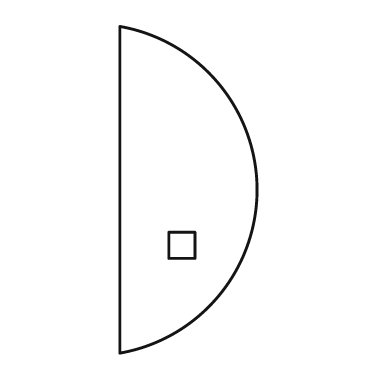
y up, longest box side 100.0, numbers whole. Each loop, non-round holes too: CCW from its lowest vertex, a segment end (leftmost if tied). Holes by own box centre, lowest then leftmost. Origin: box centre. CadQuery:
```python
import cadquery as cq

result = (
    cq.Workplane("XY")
    .moveTo(-21.0, -50.0)
    .threePointArc((21.0, 0.0), (-21.0, 50.0))
    .close()
    .moveTo(-6.0, -21.0)
    .lineTo(2.0, -21.0)
    .lineTo(2.0, -13.0)
    .lineTo(-6.0, -13.0)
    .close()
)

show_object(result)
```